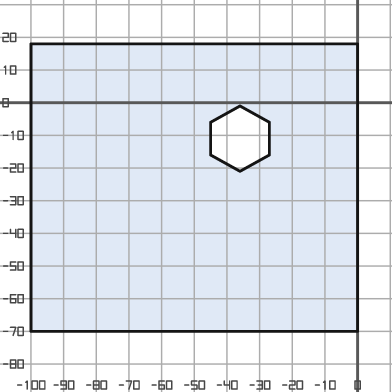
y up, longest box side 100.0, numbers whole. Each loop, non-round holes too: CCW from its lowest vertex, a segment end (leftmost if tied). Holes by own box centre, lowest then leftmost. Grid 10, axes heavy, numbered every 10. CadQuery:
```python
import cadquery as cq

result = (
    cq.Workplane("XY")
    .moveTo(-100.0, -70.0)
    .lineTo(0.0, -70.0)
    .lineTo(0.0, 18.0)
    .lineTo(-100.0, 18.0)
    .close()
    .moveTo(-36.0, -21.0)
    .lineTo(-27.0, -16.0)
    .lineTo(-27.0, -6.0)
    .lineTo(-36.0, -1.0)
    .lineTo(-45.0, -6.0)
    .lineTo(-45.0, -16.0)
    .close()
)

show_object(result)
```